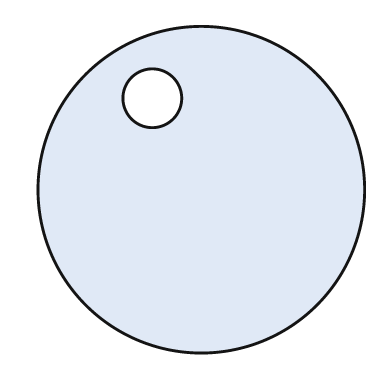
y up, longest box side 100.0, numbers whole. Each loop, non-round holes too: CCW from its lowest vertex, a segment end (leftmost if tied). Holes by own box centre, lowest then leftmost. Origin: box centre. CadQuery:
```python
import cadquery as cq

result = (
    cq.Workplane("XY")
    .moveTo(0.0, 0.0)
    .circle(50.0)
    .moveTo(-15.0, 28.0)
    .circle(9.0)
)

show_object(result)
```